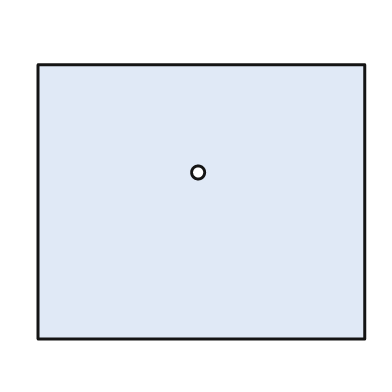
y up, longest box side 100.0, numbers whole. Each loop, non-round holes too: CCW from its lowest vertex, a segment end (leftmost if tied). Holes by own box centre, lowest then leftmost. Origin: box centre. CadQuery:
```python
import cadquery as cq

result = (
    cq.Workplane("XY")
    .moveTo(-50.0, -42.0)
    .lineTo(50.0, -42.0)
    .lineTo(50.0, 42.0)
    .lineTo(-50.0, 42.0)
    .close()
    .moveTo(-1.0, 9.0)
    .circle(2.0)
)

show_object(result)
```